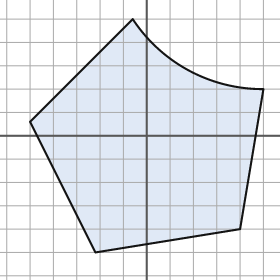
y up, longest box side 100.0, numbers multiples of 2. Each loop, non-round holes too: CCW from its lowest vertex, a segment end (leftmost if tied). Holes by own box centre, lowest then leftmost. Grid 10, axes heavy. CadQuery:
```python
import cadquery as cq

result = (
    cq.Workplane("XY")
    .moveTo(-22.0, -50.0)
    .lineTo(40.0, -40.0)
    .lineTo(50.0, 20.0)
    .threePointArc((18.0, 28.0), (-6.0, 50.0))
    .lineTo(-50.0, 6.0)
    .close()
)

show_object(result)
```